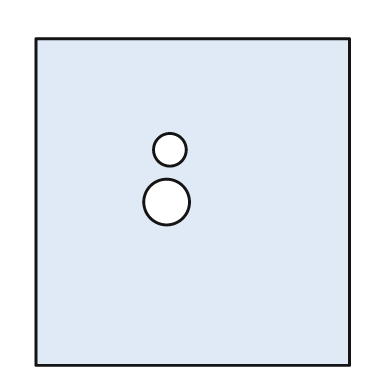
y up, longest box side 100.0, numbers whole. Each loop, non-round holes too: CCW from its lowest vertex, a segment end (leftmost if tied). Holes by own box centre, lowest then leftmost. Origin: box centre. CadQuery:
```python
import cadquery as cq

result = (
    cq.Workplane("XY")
    .moveTo(-48.0, -50.0)
    .lineTo(48.0, -50.0)
    .lineTo(48.0, 50.0)
    .lineTo(-48.0, 50.0)
    .close()
    .moveTo(-8.0, 0.0)
    .circle(7.0)
    .moveTo(-7.0, 16.0)
    .circle(5.0)
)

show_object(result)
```